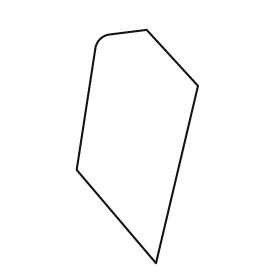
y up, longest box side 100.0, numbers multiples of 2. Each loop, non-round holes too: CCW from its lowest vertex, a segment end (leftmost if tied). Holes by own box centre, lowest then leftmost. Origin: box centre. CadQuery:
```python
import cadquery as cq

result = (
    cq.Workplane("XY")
    .moveTo(8.0, -50.0)
    .lineTo(26.0, 26.0)
    .lineTo(4.0, 50.0)
    .lineTo(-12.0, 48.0)
    .threePointArc((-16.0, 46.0), (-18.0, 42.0))
    .lineTo(-26.0, -10.0)
    .close()
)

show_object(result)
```